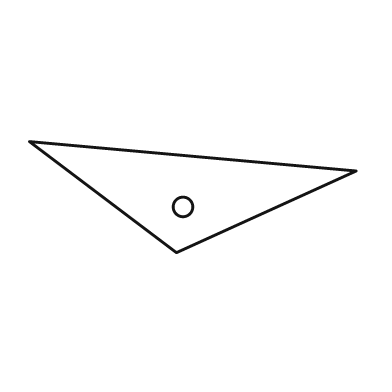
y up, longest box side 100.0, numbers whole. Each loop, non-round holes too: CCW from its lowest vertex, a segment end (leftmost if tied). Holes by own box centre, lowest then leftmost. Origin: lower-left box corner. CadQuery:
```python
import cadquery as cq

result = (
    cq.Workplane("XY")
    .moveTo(45.0, 0.0)
    .lineTo(100.0, 25.0)
    .lineTo(0.0, 34.0)
    .close()
    .moveTo(47.0, 14.0)
    .circle(3.0)
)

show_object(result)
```